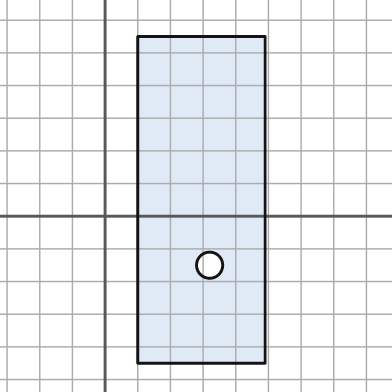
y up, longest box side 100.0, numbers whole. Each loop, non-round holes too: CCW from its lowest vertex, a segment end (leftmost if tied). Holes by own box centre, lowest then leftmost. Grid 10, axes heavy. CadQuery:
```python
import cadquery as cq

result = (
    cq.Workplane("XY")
    .moveTo(10.0, -45.0)
    .lineTo(49.0, -45.0)
    .lineTo(49.0, 55.0)
    .lineTo(10.0, 55.0)
    .close()
    .moveTo(32.0, -15.0)
    .circle(4.0)
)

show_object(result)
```